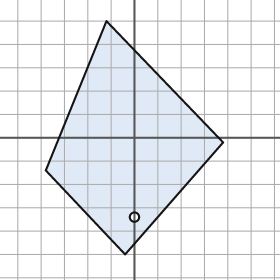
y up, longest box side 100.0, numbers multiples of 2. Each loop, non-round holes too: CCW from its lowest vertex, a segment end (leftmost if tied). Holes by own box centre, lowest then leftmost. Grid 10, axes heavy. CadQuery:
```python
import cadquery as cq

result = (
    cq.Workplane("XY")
    .moveTo(-4.0, -50.0)
    .lineTo(38.0, -2.0)
    .lineTo(-12.0, 50.0)
    .lineTo(-38.0, -14.0)
    .close()
    .moveTo(0.0, -34.0)
    .circle(2.0)
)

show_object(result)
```